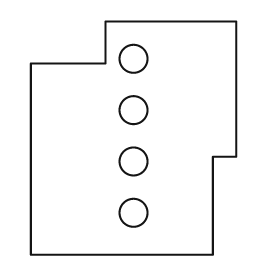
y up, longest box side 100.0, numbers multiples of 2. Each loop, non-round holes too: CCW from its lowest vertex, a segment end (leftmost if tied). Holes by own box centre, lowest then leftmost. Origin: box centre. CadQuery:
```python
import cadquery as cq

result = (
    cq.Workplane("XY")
    .moveTo(-44.0, -50.0)
    .lineTo(34.0, -50.0)
    .lineTo(34.0, -8.0)
    .lineTo(44.0, -8.0)
    .lineTo(44.0, 50.0)
    .lineTo(-12.0, 50.0)
    .lineTo(-12.0, 32.0)
    .lineTo(-44.0, 32.0)
    .close()
    .moveTo(0.0, -32.0)
    .circle(6.0)
    .moveTo(0.0, -10.0)
    .circle(6.0)
    .moveTo(0.0, 12.0)
    .circle(6.0)
    .moveTo(0.0, 34.0)
    .circle(6.0)
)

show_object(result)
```